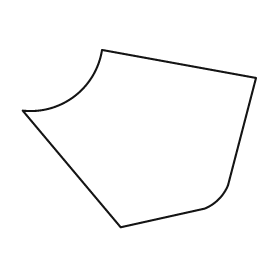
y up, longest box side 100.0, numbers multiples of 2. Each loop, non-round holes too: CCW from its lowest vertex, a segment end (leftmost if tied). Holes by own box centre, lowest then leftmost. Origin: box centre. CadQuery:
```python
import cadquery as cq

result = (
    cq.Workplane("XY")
    .moveTo(-8.0, -38.0)
    .lineTo(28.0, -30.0)
    .threePointArc((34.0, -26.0), (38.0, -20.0))
    .lineTo(50.0, 26.0)
    .lineTo(-16.0, 38.0)
    .threePointArc((-28.0, 18.0), (-50.0, 12.0))
    .close()
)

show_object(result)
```